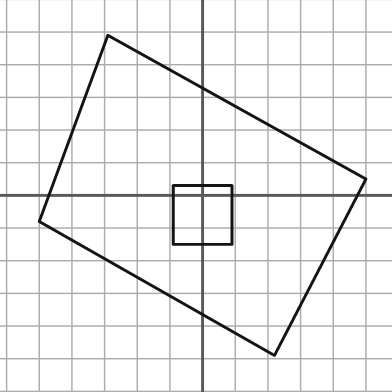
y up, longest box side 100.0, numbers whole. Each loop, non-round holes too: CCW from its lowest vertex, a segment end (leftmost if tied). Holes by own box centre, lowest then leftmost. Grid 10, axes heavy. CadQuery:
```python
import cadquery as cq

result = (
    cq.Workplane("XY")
    .moveTo(22.0, -49.0)
    .lineTo(50.0, 5.0)
    .lineTo(-29.0, 49.0)
    .lineTo(-50.0, -8.0)
    .close()
    .moveTo(-9.0, -15.0)
    .lineTo(9.0, -15.0)
    .lineTo(9.0, 3.0)
    .lineTo(-9.0, 3.0)
    .close()
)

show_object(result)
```